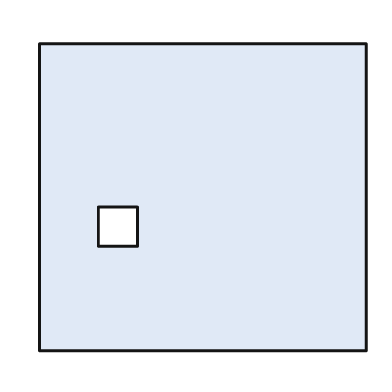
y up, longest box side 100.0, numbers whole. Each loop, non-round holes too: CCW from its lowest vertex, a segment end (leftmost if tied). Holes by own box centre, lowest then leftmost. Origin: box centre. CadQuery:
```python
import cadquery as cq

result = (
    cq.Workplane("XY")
    .moveTo(-50.0, -47.0)
    .lineTo(50.0, -47.0)
    .lineTo(50.0, 47.0)
    .lineTo(-50.0, 47.0)
    .close()
    .moveTo(-32.0, -15.0)
    .lineTo(-20.0, -15.0)
    .lineTo(-20.0, -3.0)
    .lineTo(-32.0, -3.0)
    .close()
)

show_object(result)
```